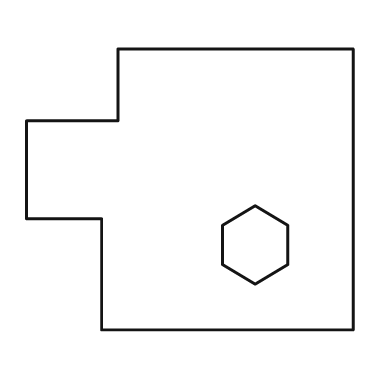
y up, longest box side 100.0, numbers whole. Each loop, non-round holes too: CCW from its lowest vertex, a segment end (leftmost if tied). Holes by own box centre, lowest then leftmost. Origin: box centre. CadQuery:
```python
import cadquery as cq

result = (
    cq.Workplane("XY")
    .moveTo(-27.0, -43.0)
    .lineTo(50.0, -43.0)
    .lineTo(50.0, 43.0)
    .lineTo(-22.0, 43.0)
    .lineTo(-22.0, 21.0)
    .lineTo(-50.0, 21.0)
    .lineTo(-50.0, -9.0)
    .lineTo(-27.0, -9.0)
    .close()
    .moveTo(20.0, -29.0)
    .lineTo(30.0, -23.0)
    .lineTo(30.0, -11.0)
    .lineTo(20.0, -5.0)
    .lineTo(10.0, -11.0)
    .lineTo(10.0, -23.0)
    .close()
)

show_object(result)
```